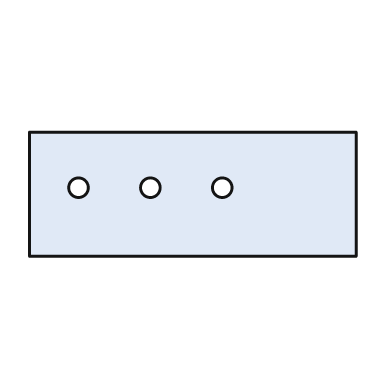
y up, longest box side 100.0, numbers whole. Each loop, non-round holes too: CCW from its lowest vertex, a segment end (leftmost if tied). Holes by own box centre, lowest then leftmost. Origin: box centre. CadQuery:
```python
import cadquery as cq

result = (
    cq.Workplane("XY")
    .moveTo(-50.0, -19.0)
    .lineTo(50.0, -19.0)
    .lineTo(50.0, 19.0)
    .lineTo(-50.0, 19.0)
    .close()
    .moveTo(-35.0, 2.0)
    .circle(3.0)
    .moveTo(-13.0, 2.0)
    .circle(3.0)
    .moveTo(9.0, 2.0)
    .circle(3.0)
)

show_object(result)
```